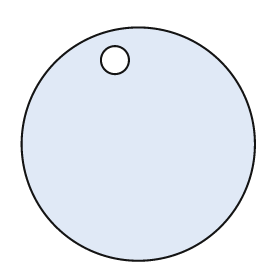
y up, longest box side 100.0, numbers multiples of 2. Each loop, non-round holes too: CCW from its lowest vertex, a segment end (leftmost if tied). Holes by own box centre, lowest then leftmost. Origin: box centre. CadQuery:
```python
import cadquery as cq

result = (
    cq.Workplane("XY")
    .moveTo(0.0, 0.0)
    .circle(50.0)
    .moveTo(-10.0, 36.0)
    .circle(6.0)
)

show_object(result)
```